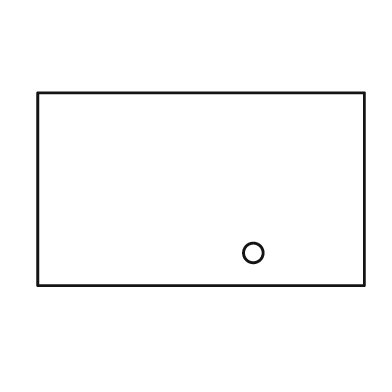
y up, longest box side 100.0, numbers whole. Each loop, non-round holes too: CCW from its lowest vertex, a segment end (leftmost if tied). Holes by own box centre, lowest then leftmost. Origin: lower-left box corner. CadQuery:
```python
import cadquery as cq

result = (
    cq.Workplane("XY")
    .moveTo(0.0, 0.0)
    .lineTo(100.0, 0.0)
    .lineTo(100.0, 59.0)
    .lineTo(0.0, 59.0)
    .close()
    .moveTo(66.0, 10.0)
    .circle(3.0)
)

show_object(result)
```